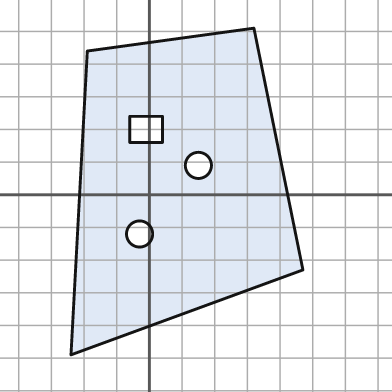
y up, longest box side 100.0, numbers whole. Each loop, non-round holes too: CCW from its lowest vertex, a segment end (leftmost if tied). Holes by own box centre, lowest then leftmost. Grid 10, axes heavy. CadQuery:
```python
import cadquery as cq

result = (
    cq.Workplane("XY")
    .moveTo(-24.0, -49.0)
    .lineTo(47.0, -23.0)
    .lineTo(32.0, 51.0)
    .lineTo(-19.0, 44.0)
    .close()
    .moveTo(-3.0, -12.0)
    .circle(4.0)
    .moveTo(15.0, 9.0)
    .circle(4.0)
    .moveTo(-6.0, 16.0)
    .lineTo(4.0, 16.0)
    .lineTo(4.0, 24.0)
    .lineTo(-6.0, 24.0)
    .close()
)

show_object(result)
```